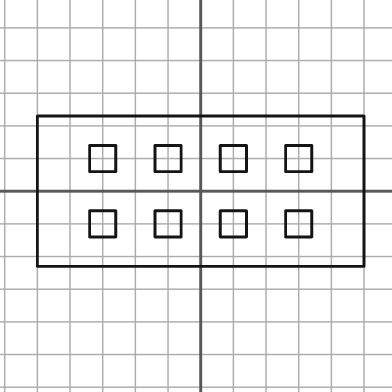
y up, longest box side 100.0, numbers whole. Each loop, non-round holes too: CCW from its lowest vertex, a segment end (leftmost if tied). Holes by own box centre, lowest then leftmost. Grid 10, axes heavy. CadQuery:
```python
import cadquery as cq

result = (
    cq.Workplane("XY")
    .moveTo(-50.0, -23.0)
    .lineTo(50.0, -23.0)
    .lineTo(50.0, 23.0)
    .lineTo(-50.0, 23.0)
    .close()
    .moveTo(-34.0, -14.0)
    .lineTo(-26.0, -14.0)
    .lineTo(-26.0, -6.0)
    .lineTo(-34.0, -6.0)
    .close()
    .moveTo(-14.0, -14.0)
    .lineTo(-6.0, -14.0)
    .lineTo(-6.0, -6.0)
    .lineTo(-14.0, -6.0)
    .close()
    .moveTo(6.0, -14.0)
    .lineTo(14.0, -14.0)
    .lineTo(14.0, -6.0)
    .lineTo(6.0, -6.0)
    .close()
    .moveTo(26.0, -14.0)
    .lineTo(34.0, -14.0)
    .lineTo(34.0, -6.0)
    .lineTo(26.0, -6.0)
    .close()
    .moveTo(-34.0, 6.0)
    .lineTo(-26.0, 6.0)
    .lineTo(-26.0, 14.0)
    .lineTo(-34.0, 14.0)
    .close()
    .moveTo(-14.0, 6.0)
    .lineTo(-6.0, 6.0)
    .lineTo(-6.0, 14.0)
    .lineTo(-14.0, 14.0)
    .close()
    .moveTo(6.0, 6.0)
    .lineTo(14.0, 6.0)
    .lineTo(14.0, 14.0)
    .lineTo(6.0, 14.0)
    .close()
    .moveTo(26.0, 6.0)
    .lineTo(34.0, 6.0)
    .lineTo(34.0, 14.0)
    .lineTo(26.0, 14.0)
    .close()
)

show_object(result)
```